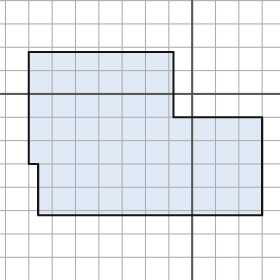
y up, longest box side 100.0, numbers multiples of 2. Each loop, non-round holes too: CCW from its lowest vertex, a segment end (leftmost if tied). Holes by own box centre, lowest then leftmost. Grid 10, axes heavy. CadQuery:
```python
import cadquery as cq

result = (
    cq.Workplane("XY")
    .moveTo(-66.0, -52.0)
    .lineTo(30.0, -52.0)
    .lineTo(30.0, -10.0)
    .lineTo(-8.0, -10.0)
    .lineTo(-8.0, 18.0)
    .lineTo(-70.0, 18.0)
    .lineTo(-70.0, -30.0)
    .lineTo(-66.0, -30.0)
    .close()
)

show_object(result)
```